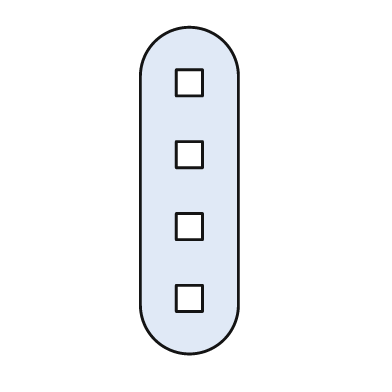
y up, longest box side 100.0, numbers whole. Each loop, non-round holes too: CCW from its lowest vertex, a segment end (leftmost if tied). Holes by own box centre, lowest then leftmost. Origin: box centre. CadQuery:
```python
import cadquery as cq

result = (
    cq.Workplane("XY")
    .moveTo(-15.0, -35.0)
    .threePointArc((0.0, -50.0), (15.0, -35.0))
    .lineTo(15.0, 35.0)
    .threePointArc((0.0, 50.0), (-15.0, 35.0))
    .close()
    .moveTo(-4.0, -37.0)
    .lineTo(4.0, -37.0)
    .lineTo(4.0, -29.0)
    .lineTo(-4.0, -29.0)
    .close()
    .moveTo(-4.0, -15.0)
    .lineTo(4.0, -15.0)
    .lineTo(4.0, -7.0)
    .lineTo(-4.0, -7.0)
    .close()
    .moveTo(-4.0, 7.0)
    .lineTo(4.0, 7.0)
    .lineTo(4.0, 15.0)
    .lineTo(-4.0, 15.0)
    .close()
    .moveTo(-4.0, 29.0)
    .lineTo(4.0, 29.0)
    .lineTo(4.0, 37.0)
    .lineTo(-4.0, 37.0)
    .close()
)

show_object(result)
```